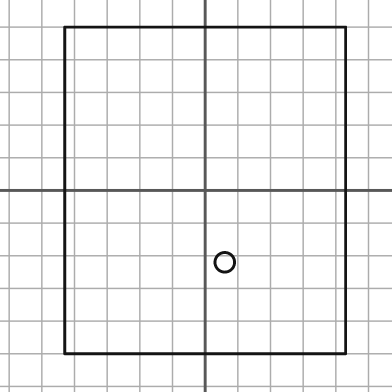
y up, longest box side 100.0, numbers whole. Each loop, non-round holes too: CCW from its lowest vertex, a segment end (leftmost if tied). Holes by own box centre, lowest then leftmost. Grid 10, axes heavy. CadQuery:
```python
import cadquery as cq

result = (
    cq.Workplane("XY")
    .moveTo(-43.0, -50.0)
    .lineTo(43.0, -50.0)
    .lineTo(43.0, 50.0)
    .lineTo(-43.0, 50.0)
    .close()
    .moveTo(6.0, -22.0)
    .circle(3.0)
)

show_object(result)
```